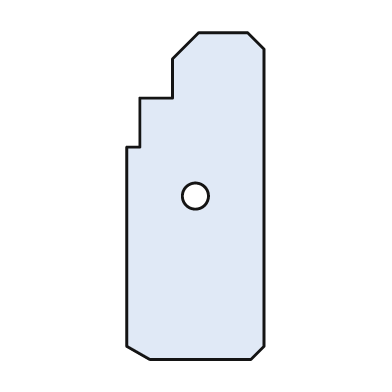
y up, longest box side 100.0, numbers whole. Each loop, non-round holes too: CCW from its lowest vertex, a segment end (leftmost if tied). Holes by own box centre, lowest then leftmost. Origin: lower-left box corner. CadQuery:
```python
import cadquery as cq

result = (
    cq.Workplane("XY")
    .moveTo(7.0, 0.0)
    .lineTo(38.0, 0.0)
    .lineTo(42.0, 4.0)
    .lineTo(42.0, 95.0)
    .lineTo(37.0, 100.0)
    .lineTo(22.0, 100.0)
    .lineTo(14.0, 92.0)
    .lineTo(14.0, 80.0)
    .lineTo(4.0, 80.0)
    .lineTo(4.0, 65.0)
    .lineTo(0.0, 65.0)
    .lineTo(0.0, 4.0)
    .close()
    .moveTo(21.0, 50.0)
    .circle(4.0)
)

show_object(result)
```